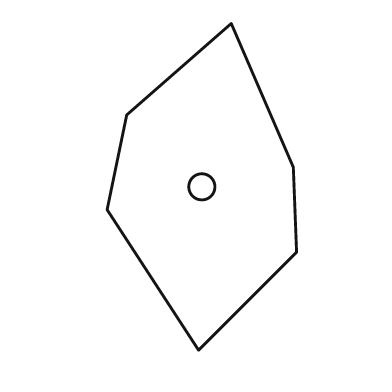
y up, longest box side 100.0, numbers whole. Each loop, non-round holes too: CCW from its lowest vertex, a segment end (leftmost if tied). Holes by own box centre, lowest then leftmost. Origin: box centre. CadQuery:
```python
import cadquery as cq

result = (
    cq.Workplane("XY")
    .moveTo(-1.0, -50.0)
    .lineTo(29.0, -20.0)
    .lineTo(28.0, 6.0)
    .lineTo(9.0, 50.0)
    .lineTo(-23.0, 22.0)
    .lineTo(-29.0, -7.0)
    .close()
    .moveTo(0.0, 0.0)
    .circle(4.0)
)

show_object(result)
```